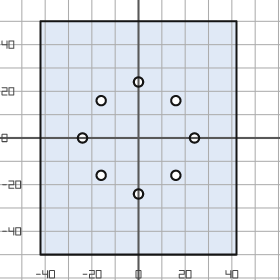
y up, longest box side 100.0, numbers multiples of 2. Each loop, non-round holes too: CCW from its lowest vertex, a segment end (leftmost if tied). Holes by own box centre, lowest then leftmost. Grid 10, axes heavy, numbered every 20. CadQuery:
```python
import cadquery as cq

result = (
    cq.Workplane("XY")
    .moveTo(-42.0, -50.0)
    .lineTo(42.0, -50.0)
    .lineTo(42.0, 50.0)
    .lineTo(-42.0, 50.0)
    .close()
    .moveTo(0.0, -24.0)
    .circle(2.0)
    .moveTo(-16.0, -16.0)
    .circle(2.0)
    .moveTo(16.0, -16.0)
    .circle(2.0)
    .moveTo(-24.0, 0.0)
    .circle(2.0)
    .moveTo(24.0, 0.0)
    .circle(2.0)
    .moveTo(-16.0, 16.0)
    .circle(2.0)
    .moveTo(16.0, 16.0)
    .circle(2.0)
    .moveTo(0.0, 24.0)
    .circle(2.0)
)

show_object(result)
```